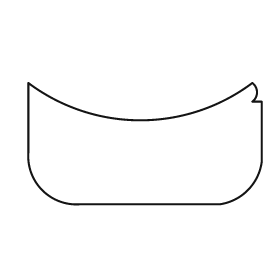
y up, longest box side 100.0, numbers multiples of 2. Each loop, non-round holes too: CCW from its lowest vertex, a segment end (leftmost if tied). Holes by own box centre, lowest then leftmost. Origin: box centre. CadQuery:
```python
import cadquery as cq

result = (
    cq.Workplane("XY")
    .moveTo(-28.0, -26.0)
    .lineTo(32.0, -26.0)
    .threePointArc((44.0, -20.0), (50.0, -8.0))
    .lineTo(50.0, 18.0)
    .lineTo(46.0, 18.0)
    .threePointArc((48.0, 22.0), (46.0, 26.0))
    .threePointArc((-2.0, 10.0), (-50.0, 26.0))
    .lineTo(-50.0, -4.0)
    .threePointArc((-44.0, -20.0), (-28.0, -26.0))
    .close()
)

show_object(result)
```